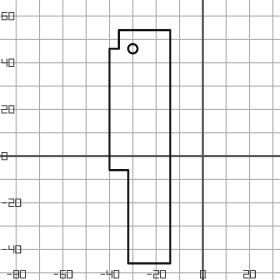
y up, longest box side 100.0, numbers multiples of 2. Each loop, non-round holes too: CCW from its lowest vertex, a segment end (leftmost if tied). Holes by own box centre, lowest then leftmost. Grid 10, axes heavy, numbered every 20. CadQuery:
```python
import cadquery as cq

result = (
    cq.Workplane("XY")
    .moveTo(-32.0, -46.0)
    .lineTo(-14.0, -46.0)
    .lineTo(-14.0, 54.0)
    .lineTo(-36.0, 54.0)
    .lineTo(-36.0, 46.0)
    .lineTo(-40.0, 46.0)
    .lineTo(-40.0, -6.0)
    .lineTo(-32.0, -6.0)
    .close()
    .moveTo(-30.0, 46.0)
    .circle(2.0)
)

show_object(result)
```